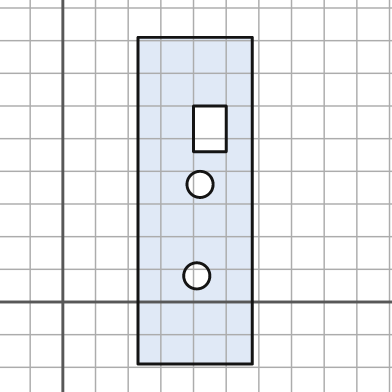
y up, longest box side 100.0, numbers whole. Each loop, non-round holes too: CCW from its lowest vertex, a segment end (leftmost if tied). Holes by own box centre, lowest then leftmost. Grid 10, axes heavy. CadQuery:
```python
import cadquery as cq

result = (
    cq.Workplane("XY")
    .moveTo(23.0, -19.0)
    .lineTo(58.0, -19.0)
    .lineTo(58.0, 81.0)
    .lineTo(23.0, 81.0)
    .close()
    .moveTo(41.0, 8.0)
    .circle(4.0)
    .moveTo(42.0, 36.0)
    .circle(4.0)
    .moveTo(40.0, 46.0)
    .lineTo(50.0, 46.0)
    .lineTo(50.0, 60.0)
    .lineTo(40.0, 60.0)
    .close()
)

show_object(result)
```